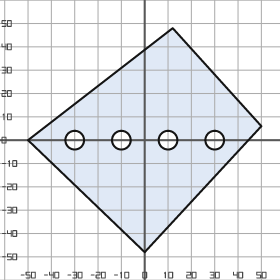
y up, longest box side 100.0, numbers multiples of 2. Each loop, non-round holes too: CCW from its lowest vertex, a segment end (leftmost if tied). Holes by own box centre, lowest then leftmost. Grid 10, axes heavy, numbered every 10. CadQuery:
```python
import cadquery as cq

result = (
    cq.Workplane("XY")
    .moveTo(0.0, -48.0)
    .lineTo(50.0, 6.0)
    .lineTo(12.0, 48.0)
    .lineTo(-50.0, 0.0)
    .close()
    .moveTo(-30.0, 0.0)
    .circle(4.0)
    .moveTo(-10.0, 0.0)
    .circle(4.0)
    .moveTo(10.0, 0.0)
    .circle(4.0)
    .moveTo(30.0, 0.0)
    .circle(4.0)
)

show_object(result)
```